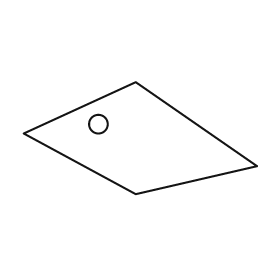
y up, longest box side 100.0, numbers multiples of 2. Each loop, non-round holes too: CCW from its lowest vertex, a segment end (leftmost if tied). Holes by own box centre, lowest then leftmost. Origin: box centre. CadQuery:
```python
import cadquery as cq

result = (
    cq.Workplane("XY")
    .moveTo(-2.0, -24.0)
    .lineTo(50.0, -12.0)
    .lineTo(-2.0, 24.0)
    .lineTo(-50.0, 2.0)
    .close()
    .moveTo(-18.0, 6.0)
    .circle(4.0)
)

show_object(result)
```